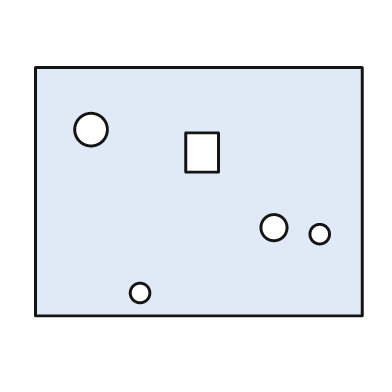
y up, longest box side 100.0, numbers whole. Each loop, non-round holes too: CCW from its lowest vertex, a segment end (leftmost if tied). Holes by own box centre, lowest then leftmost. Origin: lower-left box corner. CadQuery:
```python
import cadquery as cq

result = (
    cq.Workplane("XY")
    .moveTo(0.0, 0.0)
    .lineTo(100.0, 0.0)
    .lineTo(100.0, 76.0)
    .lineTo(0.0, 76.0)
    .close()
    .moveTo(32.0, 7.0)
    .circle(3.0)
    .moveTo(87.0, 25.0)
    .circle(3.0)
    .moveTo(73.0, 27.0)
    .circle(4.0)
    .moveTo(46.0, 44.0)
    .lineTo(56.0, 44.0)
    .lineTo(56.0, 56.0)
    .lineTo(46.0, 56.0)
    .close()
    .moveTo(17.0, 57.0)
    .circle(5.0)
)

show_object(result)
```